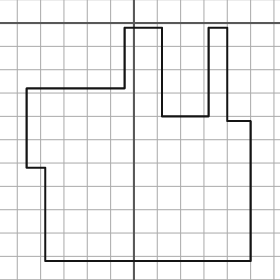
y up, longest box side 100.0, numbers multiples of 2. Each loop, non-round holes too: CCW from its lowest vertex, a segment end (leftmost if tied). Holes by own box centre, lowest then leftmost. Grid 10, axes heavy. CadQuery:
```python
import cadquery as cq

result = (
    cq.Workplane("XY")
    .moveTo(-38.0, -102.0)
    .lineTo(50.0, -102.0)
    .lineTo(50.0, -42.0)
    .lineTo(40.0, -42.0)
    .lineTo(40.0, -2.0)
    .lineTo(32.0, -2.0)
    .lineTo(32.0, -40.0)
    .lineTo(12.0, -40.0)
    .lineTo(12.0, -2.0)
    .lineTo(-4.0, -2.0)
    .lineTo(-4.0, -28.0)
    .lineTo(-46.0, -28.0)
    .lineTo(-46.0, -62.0)
    .lineTo(-38.0, -62.0)
    .close()
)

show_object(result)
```